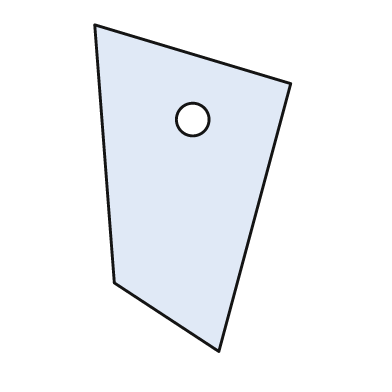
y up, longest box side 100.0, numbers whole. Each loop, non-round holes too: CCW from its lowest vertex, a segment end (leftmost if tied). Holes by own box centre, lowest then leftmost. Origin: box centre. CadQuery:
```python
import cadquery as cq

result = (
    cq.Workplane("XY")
    .moveTo(8.0, -50.0)
    .lineTo(30.0, 32.0)
    .lineTo(-30.0, 50.0)
    .lineTo(-24.0, -29.0)
    .close()
    .moveTo(0.0, 21.0)
    .circle(5.0)
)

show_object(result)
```